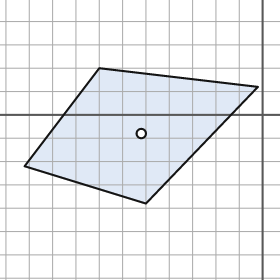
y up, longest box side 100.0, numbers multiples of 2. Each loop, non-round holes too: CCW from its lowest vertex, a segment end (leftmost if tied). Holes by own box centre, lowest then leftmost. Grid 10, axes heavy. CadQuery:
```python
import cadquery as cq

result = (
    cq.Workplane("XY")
    .moveTo(-50.0, -38.0)
    .lineTo(-2.0, 12.0)
    .lineTo(-70.0, 20.0)
    .lineTo(-102.0, -22.0)
    .close()
    .moveTo(-52.0, -8.0)
    .circle(2.0)
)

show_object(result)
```